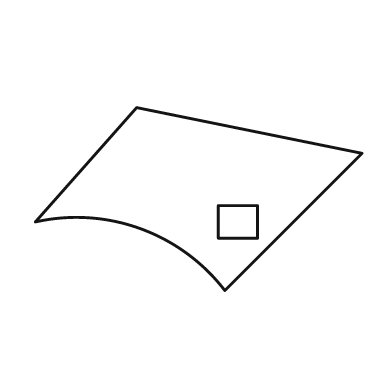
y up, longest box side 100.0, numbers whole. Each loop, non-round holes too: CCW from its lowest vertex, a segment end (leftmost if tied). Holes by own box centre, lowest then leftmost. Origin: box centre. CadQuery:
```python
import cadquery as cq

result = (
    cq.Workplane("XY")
    .moveTo(8.0, -28.0)
    .lineTo(50.0, 14.0)
    .lineTo(-19.0, 28.0)
    .lineTo(-50.0, -7.0)
    .threePointArc((-18.0, -9.0), (8.0, -28.0))
    .close()
    .moveTo(6.0, -12.0)
    .lineTo(18.0, -12.0)
    .lineTo(18.0, -2.0)
    .lineTo(6.0, -2.0)
    .close()
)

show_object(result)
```